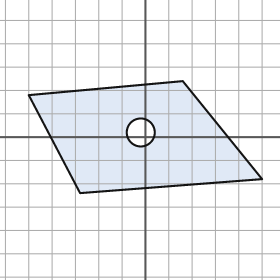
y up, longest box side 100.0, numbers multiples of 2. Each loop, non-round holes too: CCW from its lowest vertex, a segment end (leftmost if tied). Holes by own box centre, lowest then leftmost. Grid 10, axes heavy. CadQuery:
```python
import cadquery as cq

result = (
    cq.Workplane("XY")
    .moveTo(-28.0, -24.0)
    .lineTo(50.0, -18.0)
    .lineTo(16.0, 24.0)
    .lineTo(-50.0, 18.0)
    .close()
    .moveTo(-2.0, 2.0)
    .circle(6.0)
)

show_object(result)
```